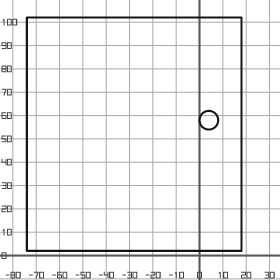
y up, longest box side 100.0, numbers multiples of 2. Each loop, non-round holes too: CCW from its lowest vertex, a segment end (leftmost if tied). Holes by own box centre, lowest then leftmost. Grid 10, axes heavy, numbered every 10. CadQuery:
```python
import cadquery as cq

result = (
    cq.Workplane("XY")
    .moveTo(-74.0, 2.0)
    .lineTo(18.0, 2.0)
    .lineTo(18.0, 102.0)
    .lineTo(-74.0, 102.0)
    .close()
    .moveTo(4.0, 58.0)
    .circle(4.0)
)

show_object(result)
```